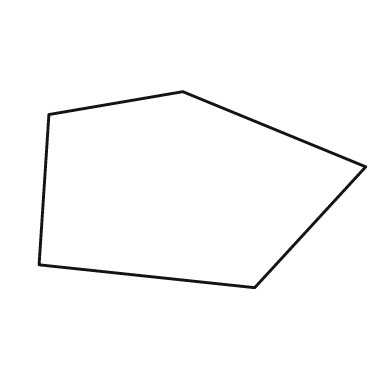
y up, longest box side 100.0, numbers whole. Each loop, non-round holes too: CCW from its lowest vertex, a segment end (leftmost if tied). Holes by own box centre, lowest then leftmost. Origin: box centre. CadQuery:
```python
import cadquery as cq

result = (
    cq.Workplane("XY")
    .moveTo(16.0, -30.0)
    .lineTo(50.0, 7.0)
    .lineTo(-6.0, 30.0)
    .lineTo(-47.0, 23.0)
    .lineTo(-50.0, -23.0)
    .close()
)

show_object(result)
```